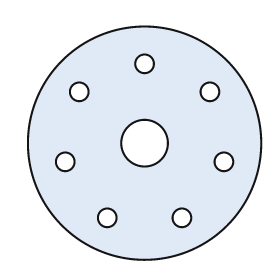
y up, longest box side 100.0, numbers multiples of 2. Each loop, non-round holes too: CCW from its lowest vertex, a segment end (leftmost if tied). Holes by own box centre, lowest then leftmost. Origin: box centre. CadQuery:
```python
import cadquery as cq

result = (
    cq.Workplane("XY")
    .moveTo(0.0, 0.0)
    .circle(50.0)
    .moveTo(-16.0, -32.0)
    .circle(4.0)
    .moveTo(16.0, -32.0)
    .circle(4.0)
    .moveTo(-34.0, -8.0)
    .circle(4.0)
    .moveTo(34.0, -8.0)
    .circle(4.0)
    .moveTo(0.0, 0.0)
    .circle(10.0)
    .moveTo(-28.0, 22.0)
    .circle(4.0)
    .moveTo(28.0, 22.0)
    .circle(4.0)
    .moveTo(0.0, 34.0)
    .circle(4.0)
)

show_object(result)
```